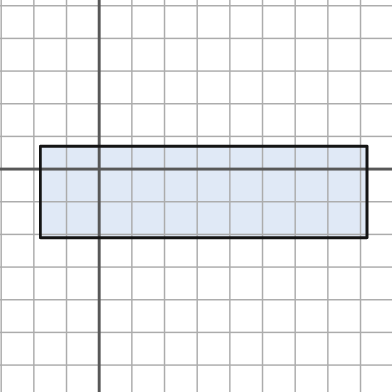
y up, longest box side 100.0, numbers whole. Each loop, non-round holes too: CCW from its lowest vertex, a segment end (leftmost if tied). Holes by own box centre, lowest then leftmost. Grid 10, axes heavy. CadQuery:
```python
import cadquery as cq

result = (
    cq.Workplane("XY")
    .moveTo(-18.0, -21.0)
    .lineTo(82.0, -21.0)
    .lineTo(82.0, 7.0)
    .lineTo(-18.0, 7.0)
    .close()
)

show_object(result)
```